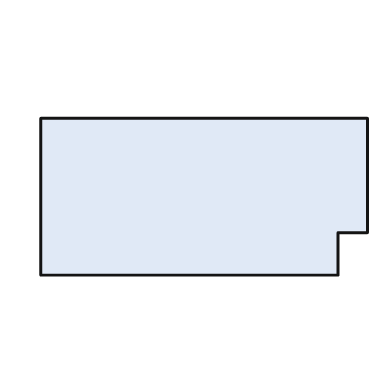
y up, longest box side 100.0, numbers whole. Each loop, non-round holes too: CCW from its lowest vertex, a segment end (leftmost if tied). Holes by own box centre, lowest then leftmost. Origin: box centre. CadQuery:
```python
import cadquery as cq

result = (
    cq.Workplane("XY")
    .moveTo(-50.0, -24.0)
    .lineTo(41.0, -24.0)
    .lineTo(41.0, -11.0)
    .lineTo(50.0, -11.0)
    .lineTo(50.0, 24.0)
    .lineTo(-50.0, 24.0)
    .close()
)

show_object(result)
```